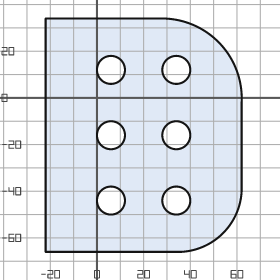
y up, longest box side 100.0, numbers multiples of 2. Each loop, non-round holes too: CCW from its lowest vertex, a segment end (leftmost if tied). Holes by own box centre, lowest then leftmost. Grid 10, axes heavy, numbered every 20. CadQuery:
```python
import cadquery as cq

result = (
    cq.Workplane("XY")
    .moveTo(-22.0, -66.0)
    .lineTo(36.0, -66.0)
    .threePointArc((54.0, -58.0), (62.0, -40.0))
    .lineTo(62.0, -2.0)
    .threePointArc((52.0, 24.0), (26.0, 34.0))
    .lineTo(-22.0, 34.0)
    .close()
    .moveTo(6.0, -44.0)
    .circle(6.0)
    .moveTo(34.0, -44.0)
    .circle(6.0)
    .moveTo(6.0, -16.0)
    .circle(6.0)
    .moveTo(34.0, -16.0)
    .circle(6.0)
    .moveTo(6.0, 12.0)
    .circle(6.0)
    .moveTo(34.0, 12.0)
    .circle(6.0)
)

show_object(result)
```